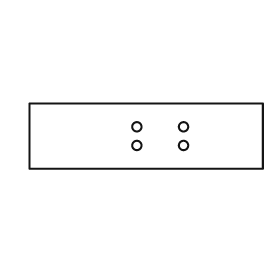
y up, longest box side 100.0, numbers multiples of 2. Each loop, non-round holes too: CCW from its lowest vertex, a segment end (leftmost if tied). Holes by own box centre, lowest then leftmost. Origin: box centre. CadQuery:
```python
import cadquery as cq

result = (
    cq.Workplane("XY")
    .moveTo(-50.0, -14.0)
    .lineTo(50.0, -14.0)
    .lineTo(50.0, 14.0)
    .lineTo(-50.0, 14.0)
    .close()
    .moveTo(-4.0, -4.0)
    .circle(2.0)
    .moveTo(16.0, -4.0)
    .circle(2.0)
    .moveTo(-4.0, 4.0)
    .circle(2.0)
    .moveTo(16.0, 4.0)
    .circle(2.0)
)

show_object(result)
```